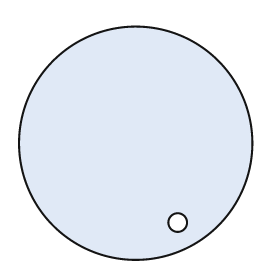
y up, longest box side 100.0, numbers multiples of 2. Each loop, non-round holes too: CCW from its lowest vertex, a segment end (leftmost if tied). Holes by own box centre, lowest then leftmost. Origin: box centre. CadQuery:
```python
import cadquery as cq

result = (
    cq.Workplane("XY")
    .moveTo(0.0, 0.0)
    .circle(50.0)
    .moveTo(18.0, -34.0)
    .circle(4.0)
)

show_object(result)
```